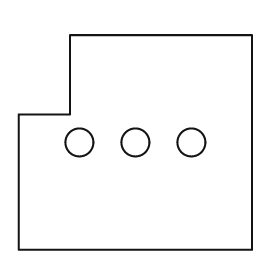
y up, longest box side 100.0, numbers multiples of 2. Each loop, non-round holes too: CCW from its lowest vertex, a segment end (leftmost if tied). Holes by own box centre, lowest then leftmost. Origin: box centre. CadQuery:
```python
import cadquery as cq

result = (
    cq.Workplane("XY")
    .moveTo(-50.0, -46.0)
    .lineTo(50.0, -46.0)
    .lineTo(50.0, 46.0)
    .lineTo(-28.0, 46.0)
    .lineTo(-28.0, 12.0)
    .lineTo(-50.0, 12.0)
    .close()
    .moveTo(-24.0, 0.0)
    .circle(6.0)
    .moveTo(0.0, 0.0)
    .circle(6.0)
    .moveTo(24.0, 0.0)
    .circle(6.0)
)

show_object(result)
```